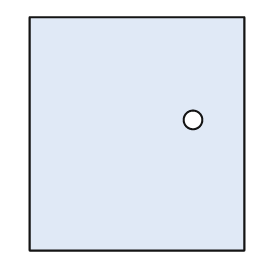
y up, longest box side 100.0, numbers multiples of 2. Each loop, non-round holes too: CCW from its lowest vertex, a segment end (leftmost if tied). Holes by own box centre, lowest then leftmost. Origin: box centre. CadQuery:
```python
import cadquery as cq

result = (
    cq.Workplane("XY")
    .moveTo(-46.0, -50.0)
    .lineTo(46.0, -50.0)
    .lineTo(46.0, 50.0)
    .lineTo(-46.0, 50.0)
    .close()
    .moveTo(24.0, 6.0)
    .circle(4.0)
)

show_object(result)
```